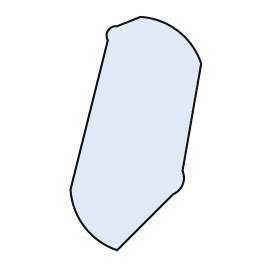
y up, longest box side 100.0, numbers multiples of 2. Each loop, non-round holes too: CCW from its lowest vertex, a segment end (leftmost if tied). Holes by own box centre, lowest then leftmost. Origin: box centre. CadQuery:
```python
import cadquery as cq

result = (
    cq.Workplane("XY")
    .moveTo(-8.0, -50.0)
    .lineTo(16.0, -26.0)
    .threePointArc((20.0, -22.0), (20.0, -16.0))
    .lineTo(28.0, 30.0)
    .threePointArc((18.0, 44.0), (2.0, 50.0))
    .lineTo(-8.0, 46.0)
    .threePointArc((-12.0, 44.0), (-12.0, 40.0))
    .lineTo(-28.0, -24.0)
    .threePointArc((-22.0, -40.0), (-8.0, -50.0))
    .close()
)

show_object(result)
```